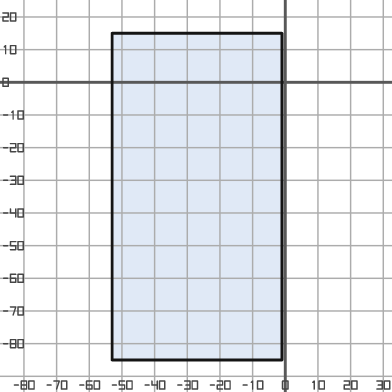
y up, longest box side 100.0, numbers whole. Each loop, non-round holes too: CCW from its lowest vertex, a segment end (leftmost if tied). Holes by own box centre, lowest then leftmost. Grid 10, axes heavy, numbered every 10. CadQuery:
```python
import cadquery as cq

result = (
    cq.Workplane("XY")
    .moveTo(-53.0, -85.0)
    .lineTo(-1.0, -85.0)
    .lineTo(-1.0, 15.0)
    .lineTo(-53.0, 15.0)
    .close()
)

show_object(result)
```